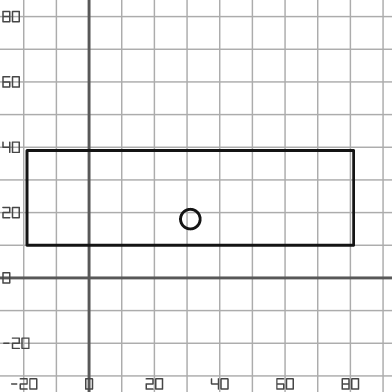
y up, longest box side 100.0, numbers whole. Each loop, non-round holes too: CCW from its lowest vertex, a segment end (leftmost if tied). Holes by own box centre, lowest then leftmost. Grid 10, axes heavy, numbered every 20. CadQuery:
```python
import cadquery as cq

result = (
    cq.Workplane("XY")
    .moveTo(-19.0, 10.0)
    .lineTo(81.0, 10.0)
    .lineTo(81.0, 39.0)
    .lineTo(-19.0, 39.0)
    .close()
    .moveTo(31.0, 18.0)
    .circle(3.0)
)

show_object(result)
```